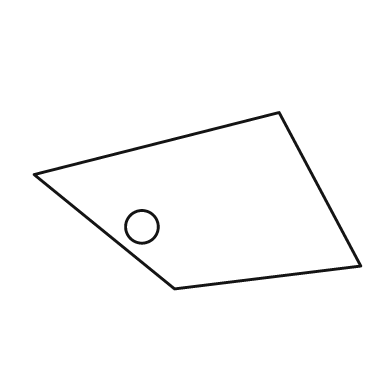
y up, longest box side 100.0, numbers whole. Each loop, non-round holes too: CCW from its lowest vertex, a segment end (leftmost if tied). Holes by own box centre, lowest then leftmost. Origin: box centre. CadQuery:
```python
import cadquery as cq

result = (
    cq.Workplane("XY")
    .moveTo(-7.0, -27.0)
    .lineTo(50.0, -20.0)
    .lineTo(25.0, 27.0)
    .lineTo(-50.0, 8.0)
    .close()
    .moveTo(-17.0, -8.0)
    .circle(5.0)
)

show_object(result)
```